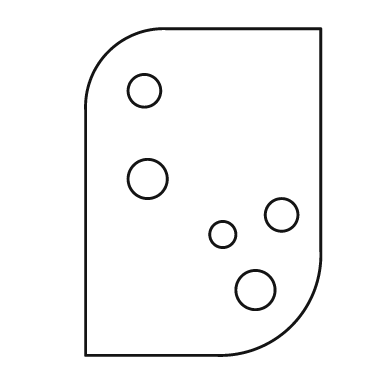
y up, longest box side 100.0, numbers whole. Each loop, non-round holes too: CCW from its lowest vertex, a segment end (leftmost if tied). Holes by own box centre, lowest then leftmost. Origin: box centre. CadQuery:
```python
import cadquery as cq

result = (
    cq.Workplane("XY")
    .moveTo(-36.0, -50.0)
    .lineTo(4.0, -50.0)
    .threePointArc((27.0, -41.0), (36.0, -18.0))
    .lineTo(36.0, 50.0)
    .lineTo(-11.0, 50.0)
    .threePointArc((-29.0, 43.0), (-36.0, 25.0))
    .close()
    .moveTo(16.0, -30.0)
    .circle(6.0)
    .moveTo(6.0, -13.0)
    .circle(4.0)
    .moveTo(24.0, -7.0)
    .circle(5.0)
    .moveTo(-17.0, 4.0)
    .circle(6.0)
    .moveTo(-18.0, 31.0)
    .circle(5.0)
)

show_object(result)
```